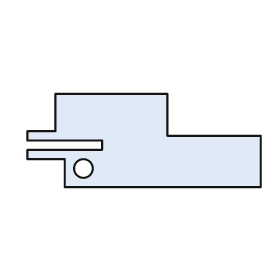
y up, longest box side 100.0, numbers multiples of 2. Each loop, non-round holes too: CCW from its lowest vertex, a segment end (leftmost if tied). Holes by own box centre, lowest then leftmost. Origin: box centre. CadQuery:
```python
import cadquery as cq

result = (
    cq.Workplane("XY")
    .moveTo(-34.0, -20.0)
    .lineTo(50.0, -20.0)
    .lineTo(50.0, 2.0)
    .lineTo(10.0, 2.0)
    .lineTo(10.0, 20.0)
    .lineTo(-38.0, 20.0)
    .lineTo(-38.0, 4.0)
    .lineTo(-50.0, 4.0)
    .lineTo(-50.0, 0.0)
    .lineTo(-18.0, 0.0)
    .lineTo(-18.0, -4.0)
    .lineTo(-50.0, -4.0)
    .lineTo(-50.0, -8.0)
    .lineTo(-34.0, -8.0)
    .close()
    .moveTo(-26.0, -12.0)
    .circle(4.0)
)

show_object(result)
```